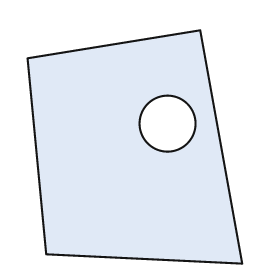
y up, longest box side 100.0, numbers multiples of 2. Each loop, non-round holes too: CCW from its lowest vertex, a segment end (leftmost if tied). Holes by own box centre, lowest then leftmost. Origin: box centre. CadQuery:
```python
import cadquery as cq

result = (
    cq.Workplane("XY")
    .moveTo(46.0, -50.0)
    .lineTo(28.0, 50.0)
    .lineTo(-46.0, 38.0)
    .lineTo(-38.0, -46.0)
    .close()
    .moveTo(14.0, 10.0)
    .circle(12.0)
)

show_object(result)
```